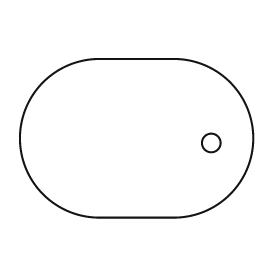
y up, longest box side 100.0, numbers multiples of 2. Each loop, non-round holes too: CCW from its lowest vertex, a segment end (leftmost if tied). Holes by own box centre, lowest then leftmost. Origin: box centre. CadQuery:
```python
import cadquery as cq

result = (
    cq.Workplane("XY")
    .moveTo(-16.0, -34.0)
    .lineTo(16.0, -34.0)
    .threePointArc((50.0, 0.0), (16.0, 34.0))
    .lineTo(-16.0, 34.0)
    .threePointArc((-50.0, 0.0), (-16.0, -34.0))
    .close()
    .moveTo(32.0, -2.0)
    .circle(4.0)
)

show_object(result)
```